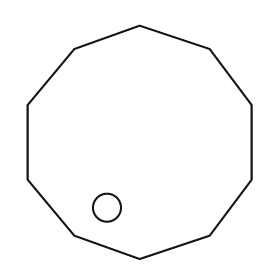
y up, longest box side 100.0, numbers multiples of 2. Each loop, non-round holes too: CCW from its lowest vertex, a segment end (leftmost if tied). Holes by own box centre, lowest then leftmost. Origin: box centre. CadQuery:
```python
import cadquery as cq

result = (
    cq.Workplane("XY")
    .moveTo(0.0, -50.0)
    .lineTo(30.0, -40.0)
    .lineTo(48.0, -16.0)
    .lineTo(48.0, 16.0)
    .lineTo(30.0, 40.0)
    .lineTo(0.0, 50.0)
    .lineTo(-28.0, 40.0)
    .lineTo(-48.0, 16.0)
    .lineTo(-48.0, -16.0)
    .lineTo(-28.0, -40.0)
    .close()
    .moveTo(-14.0, -28.0)
    .circle(6.0)
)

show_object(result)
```